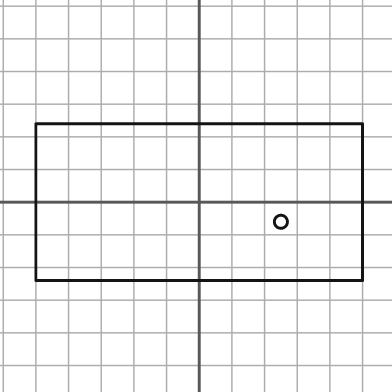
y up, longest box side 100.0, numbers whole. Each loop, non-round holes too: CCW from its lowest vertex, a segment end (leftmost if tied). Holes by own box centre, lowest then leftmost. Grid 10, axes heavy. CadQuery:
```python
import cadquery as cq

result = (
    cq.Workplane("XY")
    .moveTo(-50.0, -24.0)
    .lineTo(50.0, -24.0)
    .lineTo(50.0, 24.0)
    .lineTo(-50.0, 24.0)
    .close()
    .moveTo(25.0, -6.0)
    .circle(2.0)
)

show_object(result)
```